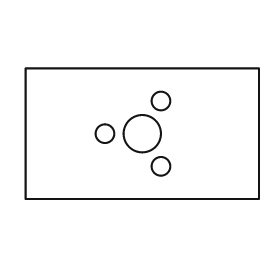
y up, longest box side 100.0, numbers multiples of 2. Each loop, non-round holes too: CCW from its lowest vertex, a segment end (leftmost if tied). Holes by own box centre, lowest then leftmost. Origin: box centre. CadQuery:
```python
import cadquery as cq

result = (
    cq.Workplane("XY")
    .moveTo(-50.0, -28.0)
    .lineTo(50.0, -28.0)
    .lineTo(50.0, 28.0)
    .lineTo(-50.0, 28.0)
    .close()
    .moveTo(8.0, -14.0)
    .circle(4.0)
    .moveTo(-16.0, 0.0)
    .circle(4.0)
    .moveTo(0.0, 0.0)
    .circle(8.0)
    .moveTo(8.0, 14.0)
    .circle(4.0)
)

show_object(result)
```